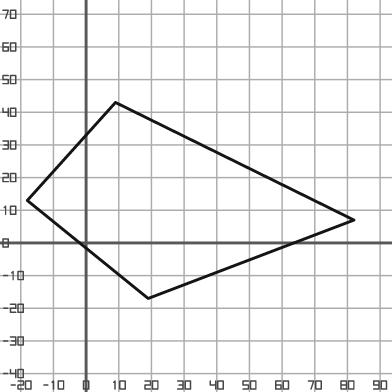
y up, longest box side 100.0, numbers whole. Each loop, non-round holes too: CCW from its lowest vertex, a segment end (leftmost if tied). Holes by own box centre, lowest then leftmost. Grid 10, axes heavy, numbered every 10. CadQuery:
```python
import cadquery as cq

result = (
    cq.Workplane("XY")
    .moveTo(19.0, -17.0)
    .lineTo(82.0, 7.0)
    .lineTo(9.0, 43.0)
    .lineTo(-18.0, 13.0)
    .close()
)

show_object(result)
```